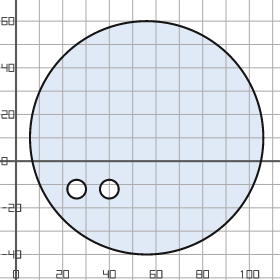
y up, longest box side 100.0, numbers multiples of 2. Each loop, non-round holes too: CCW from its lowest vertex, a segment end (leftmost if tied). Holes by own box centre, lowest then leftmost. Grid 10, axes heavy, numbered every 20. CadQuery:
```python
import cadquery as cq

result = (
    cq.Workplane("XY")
    .moveTo(56.0, 10.0)
    .circle(50.0)
    .moveTo(26.0, -12.0)
    .circle(4.0)
    .moveTo(40.0, -12.0)
    .circle(4.0)
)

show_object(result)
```